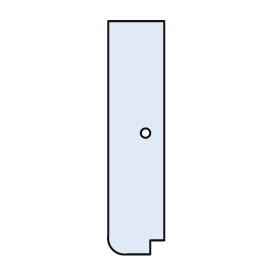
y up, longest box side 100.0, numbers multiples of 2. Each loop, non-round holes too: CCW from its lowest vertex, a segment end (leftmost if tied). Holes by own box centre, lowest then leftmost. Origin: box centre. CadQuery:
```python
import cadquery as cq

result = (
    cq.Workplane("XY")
    .moveTo(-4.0, -50.0)
    .lineTo(6.0, -50.0)
    .lineTo(6.0, -44.0)
    .lineTo(12.0, -44.0)
    .lineTo(12.0, 50.0)
    .lineTo(-12.0, 50.0)
    .lineTo(-12.0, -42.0)
    .threePointArc((-10.0, -48.0), (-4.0, -50.0))
    .close()
    .moveTo(4.0, 2.0)
    .circle(2.0)
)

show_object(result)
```